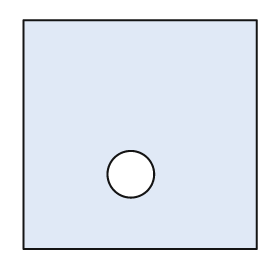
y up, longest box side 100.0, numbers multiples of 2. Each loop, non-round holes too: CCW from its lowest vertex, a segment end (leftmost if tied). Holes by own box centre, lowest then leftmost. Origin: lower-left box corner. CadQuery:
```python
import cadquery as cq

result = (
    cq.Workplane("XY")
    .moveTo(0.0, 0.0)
    .lineTo(100.0, 0.0)
    .lineTo(100.0, 98.0)
    .lineTo(0.0, 98.0)
    .close()
    .moveTo(46.0, 32.0)
    .circle(10.0)
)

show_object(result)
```